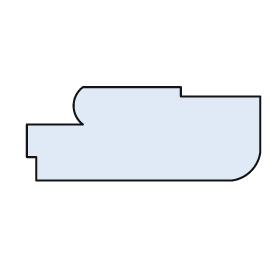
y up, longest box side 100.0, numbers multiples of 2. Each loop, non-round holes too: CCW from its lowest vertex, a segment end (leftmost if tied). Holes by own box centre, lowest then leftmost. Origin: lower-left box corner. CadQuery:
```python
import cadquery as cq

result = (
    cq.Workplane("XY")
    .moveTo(4.0, 0.0)
    .lineTo(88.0, 0.0)
    .threePointArc((96.0, 4.0), (100.0, 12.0))
    .lineTo(100.0, 36.0)
    .lineTo(66.0, 36.0)
    .lineTo(66.0, 40.0)
    .lineTo(24.0, 40.0)
    .threePointArc((20.0, 32.0), (24.0, 24.0))
    .lineTo(0.0, 24.0)
    .lineTo(0.0, 10.0)
    .lineTo(4.0, 10.0)
    .close()
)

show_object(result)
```